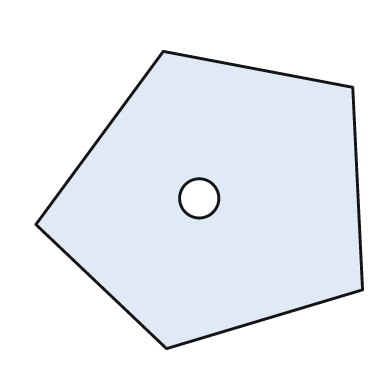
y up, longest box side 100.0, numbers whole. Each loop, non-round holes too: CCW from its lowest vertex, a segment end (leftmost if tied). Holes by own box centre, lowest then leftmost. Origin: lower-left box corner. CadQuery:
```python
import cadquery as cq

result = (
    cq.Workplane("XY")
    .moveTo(40.0, 0.0)
    .lineTo(100.0, 18.0)
    .lineTo(97.0, 80.0)
    .lineTo(39.0, 91.0)
    .lineTo(0.0, 38.0)
    .close()
    .moveTo(50.0, 46.0)
    .circle(6.0)
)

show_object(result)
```